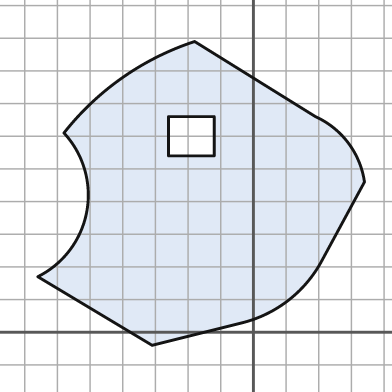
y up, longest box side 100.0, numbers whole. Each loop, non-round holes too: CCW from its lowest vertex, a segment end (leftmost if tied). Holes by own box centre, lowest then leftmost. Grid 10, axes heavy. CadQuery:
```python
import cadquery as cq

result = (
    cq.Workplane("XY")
    .moveTo(-31.0, -4.0)
    .lineTo(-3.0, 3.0)
    .threePointArc((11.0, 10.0), (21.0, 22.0))
    .lineTo(34.0, 46.0)
    .threePointArc((29.0, 58.0), (19.0, 66.0))
    .lineTo(-18.0, 89.0)
    .threePointArc((-40.0, 78.0), (-58.0, 61.0))
    .threePointArc((-51.0, 37.0), (-66.0, 17.0))
    .close()
    .moveTo(-26.0, 54.0)
    .lineTo(-12.0, 54.0)
    .lineTo(-12.0, 66.0)
    .lineTo(-26.0, 66.0)
    .close()
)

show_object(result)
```